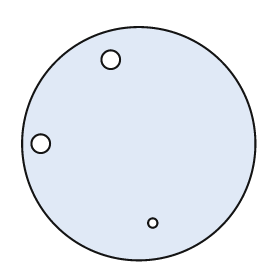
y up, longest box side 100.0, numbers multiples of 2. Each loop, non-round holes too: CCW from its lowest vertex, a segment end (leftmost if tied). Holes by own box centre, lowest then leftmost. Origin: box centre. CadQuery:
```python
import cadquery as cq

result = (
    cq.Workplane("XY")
    .moveTo(0.0, 0.0)
    .circle(50.0)
    .moveTo(6.0, -34.0)
    .circle(2.0)
    .moveTo(-42.0, 0.0)
    .circle(4.0)
    .moveTo(-12.0, 36.0)
    .circle(4.0)
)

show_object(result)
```